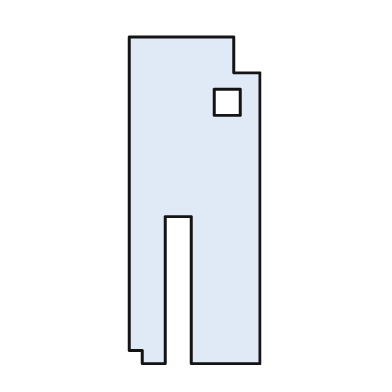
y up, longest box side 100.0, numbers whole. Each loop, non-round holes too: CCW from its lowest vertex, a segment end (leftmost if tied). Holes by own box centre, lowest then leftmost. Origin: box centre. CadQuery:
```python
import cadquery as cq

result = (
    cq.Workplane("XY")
    .moveTo(-16.0, -50.0)
    .lineTo(-9.0, -50.0)
    .lineTo(-9.0, -5.0)
    .lineTo(-1.0, -5.0)
    .lineTo(-1.0, -50.0)
    .lineTo(20.0, -50.0)
    .lineTo(20.0, 39.0)
    .lineTo(12.0, 39.0)
    .lineTo(12.0, 50.0)
    .lineTo(-20.0, 50.0)
    .lineTo(-20.0, -46.0)
    .lineTo(-16.0, -46.0)
    .close()
    .moveTo(6.0, 26.0)
    .lineTo(14.0, 26.0)
    .lineTo(14.0, 34.0)
    .lineTo(6.0, 34.0)
    .close()
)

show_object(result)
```